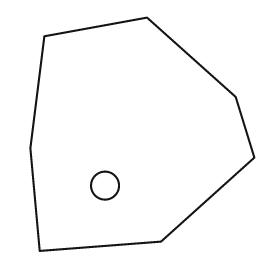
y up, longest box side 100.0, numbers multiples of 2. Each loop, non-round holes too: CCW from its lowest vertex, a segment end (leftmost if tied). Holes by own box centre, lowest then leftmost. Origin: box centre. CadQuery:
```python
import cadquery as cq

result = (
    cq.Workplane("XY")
    .moveTo(-44.0, -50.0)
    .lineTo(8.0, -46.0)
    .lineTo(48.0, -10.0)
    .lineTo(40.0, 16.0)
    .lineTo(2.0, 50.0)
    .lineTo(-42.0, 42.0)
    .lineTo(-48.0, -6.0)
    .close()
    .moveTo(-16.0, -22.0)
    .circle(6.0)
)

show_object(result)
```